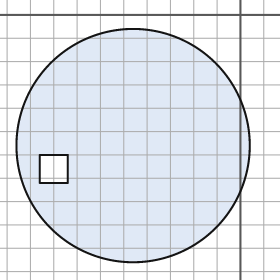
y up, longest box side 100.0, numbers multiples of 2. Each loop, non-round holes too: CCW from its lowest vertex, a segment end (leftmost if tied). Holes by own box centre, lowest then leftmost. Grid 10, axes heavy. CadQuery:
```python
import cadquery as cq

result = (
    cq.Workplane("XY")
    .moveTo(-46.0, -56.0)
    .circle(50.0)
    .moveTo(-86.0, -72.0)
    .lineTo(-74.0, -72.0)
    .lineTo(-74.0, -60.0)
    .lineTo(-86.0, -60.0)
    .close()
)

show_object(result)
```